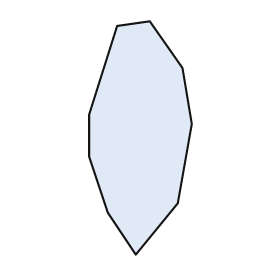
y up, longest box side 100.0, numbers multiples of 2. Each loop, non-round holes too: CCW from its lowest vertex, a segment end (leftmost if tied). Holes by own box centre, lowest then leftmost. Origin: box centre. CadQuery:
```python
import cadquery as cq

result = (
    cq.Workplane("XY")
    .moveTo(-2.0, -50.0)
    .lineTo(16.0, -28.0)
    .lineTo(22.0, 6.0)
    .lineTo(18.0, 30.0)
    .lineTo(4.0, 50.0)
    .lineTo(-10.0, 48.0)
    .lineTo(-22.0, 10.0)
    .lineTo(-22.0, -8.0)
    .lineTo(-14.0, -32.0)
    .close()
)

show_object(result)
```